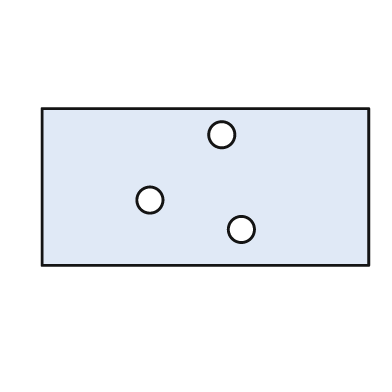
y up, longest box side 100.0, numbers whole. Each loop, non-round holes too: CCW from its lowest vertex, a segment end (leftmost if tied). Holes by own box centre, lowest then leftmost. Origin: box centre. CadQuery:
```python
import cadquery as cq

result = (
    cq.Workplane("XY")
    .moveTo(-50.0, -24.0)
    .lineTo(50.0, -24.0)
    .lineTo(50.0, 24.0)
    .lineTo(-50.0, 24.0)
    .close()
    .moveTo(11.0, -13.0)
    .circle(4.0)
    .moveTo(-17.0, -4.0)
    .circle(4.0)
    .moveTo(5.0, 16.0)
    .circle(4.0)
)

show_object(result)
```